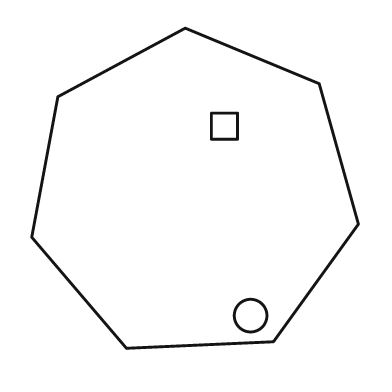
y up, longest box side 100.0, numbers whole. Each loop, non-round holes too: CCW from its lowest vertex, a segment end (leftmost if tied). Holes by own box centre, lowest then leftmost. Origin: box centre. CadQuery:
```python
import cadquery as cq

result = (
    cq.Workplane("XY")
    .moveTo(-21.0, -49.0)
    .lineTo(24.0, -47.0)
    .lineTo(50.0, -11.0)
    .lineTo(38.0, 32.0)
    .lineTo(-3.0, 49.0)
    .lineTo(-42.0, 28.0)
    .lineTo(-50.0, -15.0)
    .close()
    .moveTo(17.0, -39.0)
    .circle(5.0)
    .moveTo(5.0, 15.0)
    .lineTo(13.0, 15.0)
    .lineTo(13.0, 23.0)
    .lineTo(5.0, 23.0)
    .close()
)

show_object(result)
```